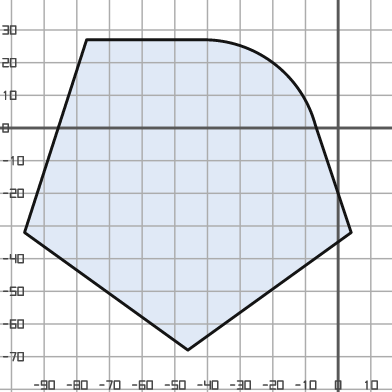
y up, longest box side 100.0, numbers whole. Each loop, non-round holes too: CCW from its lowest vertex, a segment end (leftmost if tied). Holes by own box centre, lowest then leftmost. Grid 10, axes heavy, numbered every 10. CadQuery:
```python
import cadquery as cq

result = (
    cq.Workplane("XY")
    .moveTo(-46.0, -68.0)
    .lineTo(4.0, -32.0)
    .lineTo(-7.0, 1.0)
    .threePointArc((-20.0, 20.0), (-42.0, 27.0))
    .lineTo(-77.0, 27.0)
    .lineTo(-96.0, -32.0)
    .close()
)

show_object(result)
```